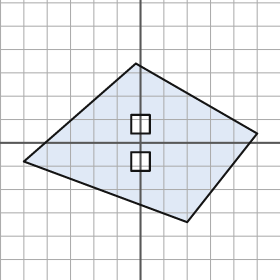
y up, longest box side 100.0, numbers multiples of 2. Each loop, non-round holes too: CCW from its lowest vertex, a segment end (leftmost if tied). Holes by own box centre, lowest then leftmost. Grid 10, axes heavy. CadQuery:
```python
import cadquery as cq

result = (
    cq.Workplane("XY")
    .moveTo(20.0, -34.0)
    .lineTo(50.0, 4.0)
    .lineTo(-2.0, 34.0)
    .lineTo(-50.0, -8.0)
    .close()
    .moveTo(-4.0, -12.0)
    .lineTo(4.0, -12.0)
    .lineTo(4.0, -4.0)
    .lineTo(-4.0, -4.0)
    .close()
    .moveTo(-4.0, 4.0)
    .lineTo(4.0, 4.0)
    .lineTo(4.0, 12.0)
    .lineTo(-4.0, 12.0)
    .close()
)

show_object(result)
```